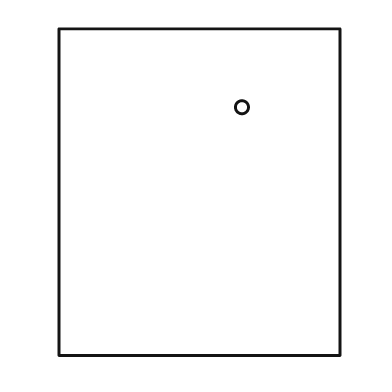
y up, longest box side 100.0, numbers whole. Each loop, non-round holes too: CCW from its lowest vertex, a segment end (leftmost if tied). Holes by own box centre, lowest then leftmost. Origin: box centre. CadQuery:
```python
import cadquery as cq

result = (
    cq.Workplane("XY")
    .moveTo(-43.0, -50.0)
    .lineTo(43.0, -50.0)
    .lineTo(43.0, 50.0)
    .lineTo(-43.0, 50.0)
    .close()
    .moveTo(13.0, 26.0)
    .circle(2.0)
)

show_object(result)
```